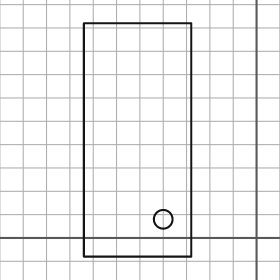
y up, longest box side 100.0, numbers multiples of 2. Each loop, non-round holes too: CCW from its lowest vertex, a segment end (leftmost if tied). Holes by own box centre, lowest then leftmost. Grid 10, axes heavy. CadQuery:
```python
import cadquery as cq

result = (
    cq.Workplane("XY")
    .moveTo(-74.0, -8.0)
    .lineTo(-28.0, -8.0)
    .lineTo(-28.0, 92.0)
    .lineTo(-74.0, 92.0)
    .close()
    .moveTo(-40.0, 8.0)
    .circle(4.0)
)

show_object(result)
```